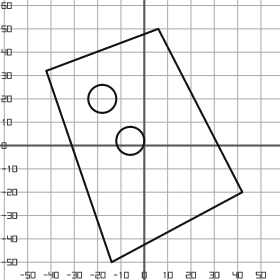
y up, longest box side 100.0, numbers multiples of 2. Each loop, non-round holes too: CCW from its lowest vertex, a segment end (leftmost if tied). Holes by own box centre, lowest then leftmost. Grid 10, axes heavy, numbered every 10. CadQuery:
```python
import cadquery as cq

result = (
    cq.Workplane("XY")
    .moveTo(-14.0, -50.0)
    .lineTo(42.0, -20.0)
    .lineTo(6.0, 50.0)
    .lineTo(-42.0, 32.0)
    .close()
    .moveTo(-6.0, 2.0)
    .circle(6.0)
    .moveTo(-18.0, 20.0)
    .circle(6.0)
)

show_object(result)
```